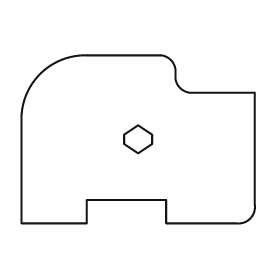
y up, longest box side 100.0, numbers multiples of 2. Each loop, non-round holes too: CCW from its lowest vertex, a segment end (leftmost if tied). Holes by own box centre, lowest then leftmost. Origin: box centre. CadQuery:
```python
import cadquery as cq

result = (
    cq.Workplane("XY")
    .moveTo(-50.0, -36.0)
    .lineTo(-22.0, -36.0)
    .lineTo(-22.0, -26.0)
    .lineTo(12.0, -26.0)
    .lineTo(12.0, -36.0)
    .lineTo(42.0, -36.0)
    .threePointArc((48.0, -34.0), (50.0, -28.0))
    .lineTo(50.0, 20.0)
    .lineTo(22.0, 20.0)
    .threePointArc((18.0, 22.0), (16.0, 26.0))
    .lineTo(16.0, 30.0)
    .threePointArc((14.0, 34.0), (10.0, 36.0))
    .lineTo(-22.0, 36.0)
    .threePointArc((-42.0, 28.0), (-50.0, 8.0))
    .close()
    .moveTo(0.0, -6.0)
    .lineTo(6.0, -2.0)
    .lineTo(6.0, 2.0)
    .lineTo(0.0, 6.0)
    .lineTo(-6.0, 2.0)
    .lineTo(-6.0, -2.0)
    .close()
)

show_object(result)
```